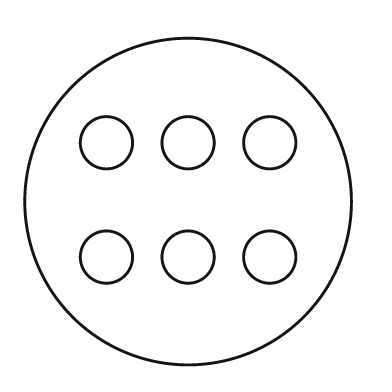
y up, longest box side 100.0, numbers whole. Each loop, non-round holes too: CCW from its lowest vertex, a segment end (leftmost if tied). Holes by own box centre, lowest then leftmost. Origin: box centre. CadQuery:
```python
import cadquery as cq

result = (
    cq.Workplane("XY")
    .moveTo(0.0, 0.0)
    .circle(50.0)
    .moveTo(-25.0, -17.0)
    .circle(8.0)
    .moveTo(0.0, -17.0)
    .circle(8.0)
    .moveTo(25.0, -17.0)
    .circle(8.0)
    .moveTo(-25.0, 18.0)
    .circle(8.0)
    .moveTo(0.0, 18.0)
    .circle(8.0)
    .moveTo(25.0, 18.0)
    .circle(8.0)
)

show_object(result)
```